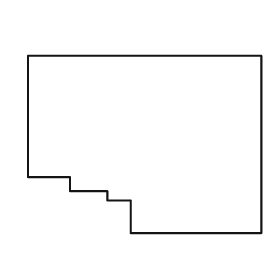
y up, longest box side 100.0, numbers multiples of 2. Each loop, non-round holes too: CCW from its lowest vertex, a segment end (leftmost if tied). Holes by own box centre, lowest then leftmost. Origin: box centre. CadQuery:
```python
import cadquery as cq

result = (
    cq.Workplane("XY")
    .moveTo(-6.0, -38.0)
    .lineTo(50.0, -38.0)
    .lineTo(50.0, 38.0)
    .lineTo(-50.0, 38.0)
    .lineTo(-50.0, -14.0)
    .lineTo(-32.0, -14.0)
    .lineTo(-32.0, -20.0)
    .lineTo(-16.0, -20.0)
    .lineTo(-16.0, -24.0)
    .lineTo(-6.0, -24.0)
    .close()
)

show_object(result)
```